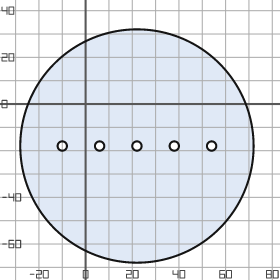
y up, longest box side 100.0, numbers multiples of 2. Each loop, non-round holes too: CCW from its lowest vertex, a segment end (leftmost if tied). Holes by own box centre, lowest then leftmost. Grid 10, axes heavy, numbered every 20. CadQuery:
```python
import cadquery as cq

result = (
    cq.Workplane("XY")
    .moveTo(22.0, -18.0)
    .circle(50.0)
    .moveTo(-10.0, -18.0)
    .circle(2.0)
    .moveTo(6.0, -18.0)
    .circle(2.0)
    .moveTo(22.0, -18.0)
    .circle(2.0)
    .moveTo(38.0, -18.0)
    .circle(2.0)
    .moveTo(54.0, -18.0)
    .circle(2.0)
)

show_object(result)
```